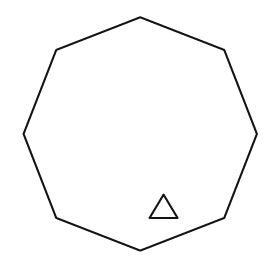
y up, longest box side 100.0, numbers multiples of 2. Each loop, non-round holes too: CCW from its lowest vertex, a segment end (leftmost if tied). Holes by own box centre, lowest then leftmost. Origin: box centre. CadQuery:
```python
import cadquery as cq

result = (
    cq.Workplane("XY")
    .moveTo(0.0, -50.0)
    .lineTo(36.0, -36.0)
    .lineTo(50.0, 0.0)
    .lineTo(36.0, 36.0)
    .lineTo(0.0, 50.0)
    .lineTo(-36.0, 36.0)
    .lineTo(-50.0, 0.0)
    .lineTo(-36.0, -36.0)
    .close()
    .moveTo(4.0, -36.0)
    .lineTo(16.0, -36.0)
    .lineTo(10.0, -26.0)
    .close()
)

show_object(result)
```